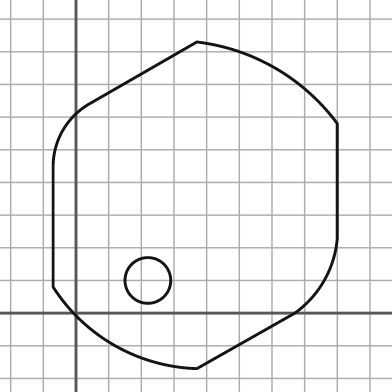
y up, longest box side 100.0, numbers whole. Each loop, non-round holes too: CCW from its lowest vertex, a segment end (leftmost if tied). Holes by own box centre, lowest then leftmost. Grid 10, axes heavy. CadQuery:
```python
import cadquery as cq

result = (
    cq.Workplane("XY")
    .moveTo(37.0, -17.0)
    .lineTo(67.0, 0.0)
    .threePointArc((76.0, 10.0), (80.0, 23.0))
    .lineTo(80.0, 58.0)
    .threePointArc((61.0, 75.0), (37.0, 83.0))
    .lineTo(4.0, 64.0)
    .threePointArc((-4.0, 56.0), (-7.0, 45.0))
    .lineTo(-7.0, 8.0)
    .threePointArc((12.0, -10.0), (37.0, -17.0))
    .close()
    .moveTo(22.0, 10.0)
    .circle(7.0)
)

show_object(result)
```